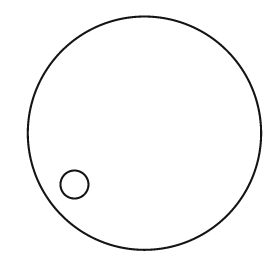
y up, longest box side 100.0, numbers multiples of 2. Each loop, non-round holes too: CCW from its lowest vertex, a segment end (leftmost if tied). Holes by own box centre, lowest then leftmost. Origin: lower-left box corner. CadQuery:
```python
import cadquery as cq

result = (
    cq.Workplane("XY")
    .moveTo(50.0, 50.0)
    .circle(50.0)
    .moveTo(20.0, 28.0)
    .circle(6.0)
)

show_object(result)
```